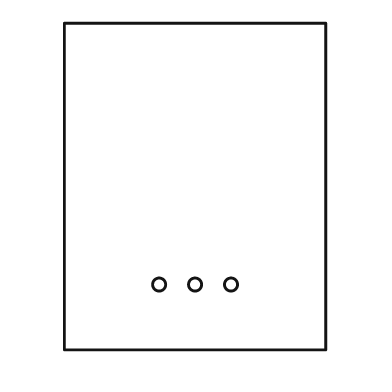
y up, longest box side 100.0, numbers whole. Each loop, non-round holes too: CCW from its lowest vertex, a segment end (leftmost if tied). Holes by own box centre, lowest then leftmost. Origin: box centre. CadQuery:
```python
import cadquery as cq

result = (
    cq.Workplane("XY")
    .moveTo(-40.0, -50.0)
    .lineTo(40.0, -50.0)
    .lineTo(40.0, 50.0)
    .lineTo(-40.0, 50.0)
    .close()
    .moveTo(-11.0, -30.0)
    .circle(2.0)
    .moveTo(0.0, -30.0)
    .circle(2.0)
    .moveTo(11.0, -30.0)
    .circle(2.0)
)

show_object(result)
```